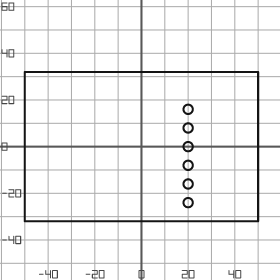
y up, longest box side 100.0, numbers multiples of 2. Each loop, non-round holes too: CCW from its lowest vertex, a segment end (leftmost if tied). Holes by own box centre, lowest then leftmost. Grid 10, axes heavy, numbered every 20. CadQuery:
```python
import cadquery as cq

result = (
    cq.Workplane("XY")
    .moveTo(-50.0, -32.0)
    .lineTo(50.0, -32.0)
    .lineTo(50.0, 32.0)
    .lineTo(-50.0, 32.0)
    .close()
    .moveTo(20.0, -24.0)
    .circle(2.0)
    .moveTo(20.0, -16.0)
    .circle(2.0)
    .moveTo(20.0, -8.0)
    .circle(2.0)
    .moveTo(20.0, 0.0)
    .circle(2.0)
    .moveTo(20.0, 8.0)
    .circle(2.0)
    .moveTo(20.0, 16.0)
    .circle(2.0)
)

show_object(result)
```